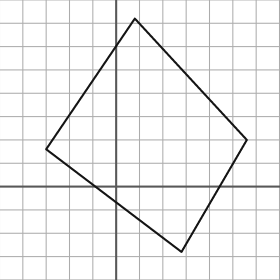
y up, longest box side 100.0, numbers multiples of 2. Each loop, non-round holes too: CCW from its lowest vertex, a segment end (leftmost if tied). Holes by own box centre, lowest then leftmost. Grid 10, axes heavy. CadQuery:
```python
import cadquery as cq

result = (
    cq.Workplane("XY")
    .moveTo(28.0, -28.0)
    .lineTo(56.0, 20.0)
    .lineTo(8.0, 72.0)
    .lineTo(-30.0, 16.0)
    .close()
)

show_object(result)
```